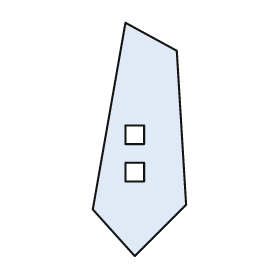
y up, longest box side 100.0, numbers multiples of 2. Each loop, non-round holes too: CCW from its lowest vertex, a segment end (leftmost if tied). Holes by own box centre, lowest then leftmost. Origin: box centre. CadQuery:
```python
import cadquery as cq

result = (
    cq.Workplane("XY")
    .moveTo(-2.0, -50.0)
    .lineTo(20.0, -28.0)
    .lineTo(16.0, 38.0)
    .lineTo(-6.0, 50.0)
    .lineTo(-20.0, -30.0)
    .close()
    .moveTo(-6.0, -18.0)
    .lineTo(2.0, -18.0)
    .lineTo(2.0, -10.0)
    .lineTo(-6.0, -10.0)
    .close()
    .moveTo(-6.0, -2.0)
    .lineTo(2.0, -2.0)
    .lineTo(2.0, 6.0)
    .lineTo(-6.0, 6.0)
    .close()
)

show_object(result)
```